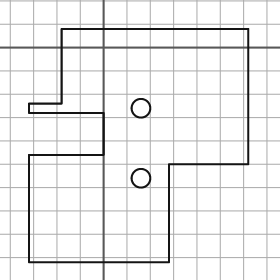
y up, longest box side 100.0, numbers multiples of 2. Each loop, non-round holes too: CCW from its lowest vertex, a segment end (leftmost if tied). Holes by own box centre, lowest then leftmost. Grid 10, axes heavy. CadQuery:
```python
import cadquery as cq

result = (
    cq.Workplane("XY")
    .moveTo(-32.0, -92.0)
    .lineTo(28.0, -92.0)
    .lineTo(28.0, -50.0)
    .lineTo(62.0, -50.0)
    .lineTo(62.0, 8.0)
    .lineTo(-18.0, 8.0)
    .lineTo(-18.0, -24.0)
    .lineTo(-32.0, -24.0)
    .lineTo(-32.0, -28.0)
    .lineTo(0.0, -28.0)
    .lineTo(0.0, -46.0)
    .lineTo(-32.0, -46.0)
    .close()
    .moveTo(16.0, -56.0)
    .circle(4.0)
    .moveTo(16.0, -26.0)
    .circle(4.0)
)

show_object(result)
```